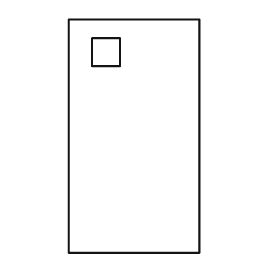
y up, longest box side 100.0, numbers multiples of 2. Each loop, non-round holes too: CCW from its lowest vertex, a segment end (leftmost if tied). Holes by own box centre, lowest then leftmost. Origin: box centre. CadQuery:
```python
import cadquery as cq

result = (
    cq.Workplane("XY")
    .moveTo(-28.0, -50.0)
    .lineTo(28.0, -50.0)
    .lineTo(28.0, 50.0)
    .lineTo(-28.0, 50.0)
    .close()
    .moveTo(-18.0, 30.0)
    .lineTo(-6.0, 30.0)
    .lineTo(-6.0, 42.0)
    .lineTo(-18.0, 42.0)
    .close()
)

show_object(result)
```